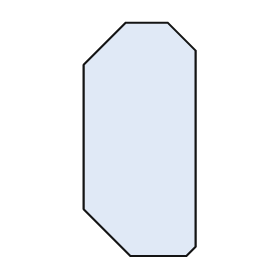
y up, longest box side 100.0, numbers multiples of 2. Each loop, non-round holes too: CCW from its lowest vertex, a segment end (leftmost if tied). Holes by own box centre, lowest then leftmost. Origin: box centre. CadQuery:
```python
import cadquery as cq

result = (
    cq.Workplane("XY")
    .moveTo(-4.0, -50.0)
    .lineTo(20.0, -50.0)
    .lineTo(24.0, -46.0)
    .lineTo(24.0, 38.0)
    .lineTo(12.0, 50.0)
    .lineTo(-6.0, 50.0)
    .lineTo(-24.0, 32.0)
    .lineTo(-24.0, -30.0)
    .close()
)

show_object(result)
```